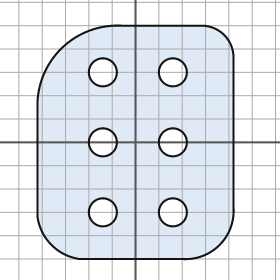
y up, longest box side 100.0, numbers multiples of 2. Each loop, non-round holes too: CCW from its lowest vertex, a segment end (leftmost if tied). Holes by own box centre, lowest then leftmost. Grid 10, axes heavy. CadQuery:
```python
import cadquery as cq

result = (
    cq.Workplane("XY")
    .moveTo(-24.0, -50.0)
    .lineTo(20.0, -50.0)
    .threePointArc((36.0, -44.0), (42.0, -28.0))
    .lineTo(42.0, 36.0)
    .threePointArc((38.0, 46.0), (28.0, 50.0))
    .lineTo(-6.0, 50.0)
    .threePointArc((-32.0, 40.0), (-42.0, 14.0))
    .lineTo(-42.0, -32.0)
    .threePointArc((-36.0, -44.0), (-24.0, -50.0))
    .close()
    .moveTo(-14.0, -30.0)
    .circle(6.0)
    .moveTo(16.0, -30.0)
    .circle(6.0)
    .moveTo(-14.0, 0.0)
    .circle(6.0)
    .moveTo(16.0, 0.0)
    .circle(6.0)
    .moveTo(-14.0, 30.0)
    .circle(6.0)
    .moveTo(16.0, 30.0)
    .circle(6.0)
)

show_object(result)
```